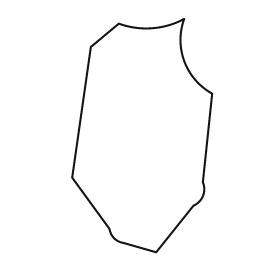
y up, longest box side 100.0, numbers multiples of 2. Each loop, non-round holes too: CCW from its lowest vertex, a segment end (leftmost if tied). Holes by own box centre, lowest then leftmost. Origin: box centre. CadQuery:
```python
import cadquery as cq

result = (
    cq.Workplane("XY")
    .moveTo(6.0, -50.0)
    .lineTo(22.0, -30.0)
    .threePointArc((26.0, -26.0), (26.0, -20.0))
    .lineTo(30.0, 18.0)
    .threePointArc((18.0, 32.0), (18.0, 50.0))
    .threePointArc((4.0, 46.0), (-10.0, 48.0))
    .lineTo(-22.0, 38.0)
    .lineTo(-30.0, -18.0)
    .lineTo(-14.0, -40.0)
    .threePointArc((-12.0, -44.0), (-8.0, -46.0))
    .close()
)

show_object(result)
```